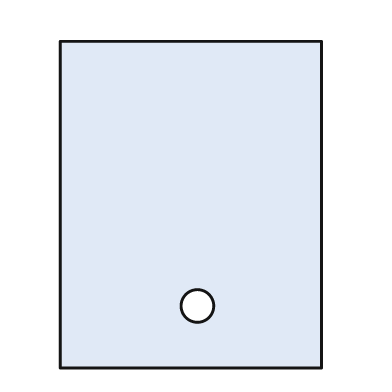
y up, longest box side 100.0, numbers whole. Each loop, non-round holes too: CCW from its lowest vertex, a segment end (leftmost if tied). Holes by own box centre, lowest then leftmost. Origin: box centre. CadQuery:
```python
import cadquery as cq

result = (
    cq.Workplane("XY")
    .moveTo(-40.0, -50.0)
    .lineTo(40.0, -50.0)
    .lineTo(40.0, 50.0)
    .lineTo(-40.0, 50.0)
    .close()
    .moveTo(2.0, -31.0)
    .circle(5.0)
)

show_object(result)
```